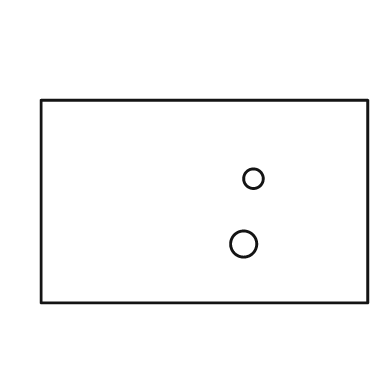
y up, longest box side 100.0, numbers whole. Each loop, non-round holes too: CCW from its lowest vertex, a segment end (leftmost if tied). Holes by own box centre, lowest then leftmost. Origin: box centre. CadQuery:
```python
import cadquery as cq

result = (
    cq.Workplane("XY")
    .moveTo(-50.0, -31.0)
    .lineTo(50.0, -31.0)
    .lineTo(50.0, 31.0)
    .lineTo(-50.0, 31.0)
    .close()
    .moveTo(12.0, -13.0)
    .circle(4.0)
    .moveTo(15.0, 7.0)
    .circle(3.0)
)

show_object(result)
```